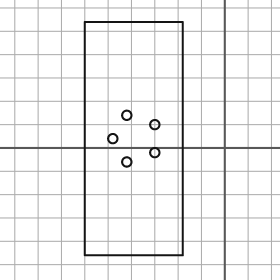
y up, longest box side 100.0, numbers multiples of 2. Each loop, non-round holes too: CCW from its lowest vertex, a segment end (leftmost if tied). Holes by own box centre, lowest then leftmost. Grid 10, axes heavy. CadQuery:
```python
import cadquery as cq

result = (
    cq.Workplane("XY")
    .moveTo(-60.0, -46.0)
    .lineTo(-18.0, -46.0)
    .lineTo(-18.0, 54.0)
    .lineTo(-60.0, 54.0)
    .close()
    .moveTo(-42.0, -6.0)
    .circle(2.0)
    .moveTo(-30.0, -2.0)
    .circle(2.0)
    .moveTo(-48.0, 4.0)
    .circle(2.0)
    .moveTo(-30.0, 10.0)
    .circle(2.0)
    .moveTo(-42.0, 14.0)
    .circle(2.0)
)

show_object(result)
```